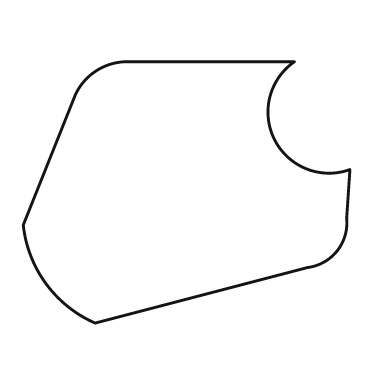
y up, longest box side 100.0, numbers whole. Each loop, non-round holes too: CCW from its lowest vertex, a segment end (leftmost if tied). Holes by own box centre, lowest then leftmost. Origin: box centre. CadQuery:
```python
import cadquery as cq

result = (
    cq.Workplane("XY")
    .moveTo(-28.0, -40.0)
    .lineTo(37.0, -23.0)
    .threePointArc((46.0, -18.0), (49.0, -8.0))
    .lineTo(50.0, 7.0)
    .threePointArc((27.0, 16.0), (33.0, 40.0))
    .lineTo(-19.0, 40.0)
    .threePointArc((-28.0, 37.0), (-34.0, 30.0))
    .lineTo(-50.0, -10.0)
    .threePointArc((-43.0, -28.0), (-28.0, -40.0))
    .close()
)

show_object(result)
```